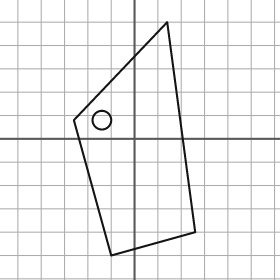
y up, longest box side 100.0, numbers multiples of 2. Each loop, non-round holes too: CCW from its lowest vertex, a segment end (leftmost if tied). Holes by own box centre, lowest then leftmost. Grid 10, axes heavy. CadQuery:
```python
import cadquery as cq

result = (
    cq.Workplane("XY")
    .moveTo(-10.0, -50.0)
    .lineTo(26.0, -40.0)
    .lineTo(14.0, 50.0)
    .lineTo(-26.0, 8.0)
    .close()
    .moveTo(-14.0, 8.0)
    .circle(4.0)
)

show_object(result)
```